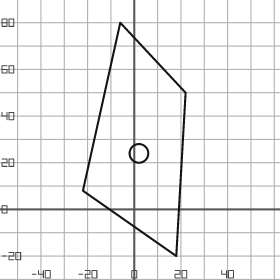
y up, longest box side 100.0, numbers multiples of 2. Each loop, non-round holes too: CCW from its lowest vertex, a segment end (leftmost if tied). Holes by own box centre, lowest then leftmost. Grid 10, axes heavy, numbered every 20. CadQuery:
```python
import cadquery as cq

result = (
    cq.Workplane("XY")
    .moveTo(18.0, -20.0)
    .lineTo(22.0, 50.0)
    .lineTo(-6.0, 80.0)
    .lineTo(-22.0, 8.0)
    .close()
    .moveTo(2.0, 24.0)
    .circle(4.0)
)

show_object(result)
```